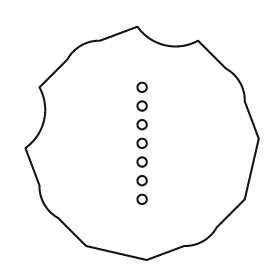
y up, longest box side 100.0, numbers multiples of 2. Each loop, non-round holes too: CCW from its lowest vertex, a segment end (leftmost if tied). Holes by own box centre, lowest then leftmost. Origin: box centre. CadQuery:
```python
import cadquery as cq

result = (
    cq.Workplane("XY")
    .moveTo(2.0, -50.0)
    .lineTo(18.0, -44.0)
    .threePointArc((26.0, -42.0), (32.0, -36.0))
    .lineTo(44.0, -24.0)
    .lineTo(50.0, 2.0)
    .lineTo(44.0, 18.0)
    .threePointArc((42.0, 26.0), (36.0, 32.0))
    .lineTo(24.0, 44.0)
    .threePointArc((10.0, 42.0), (-2.0, 50.0))
    .lineTo(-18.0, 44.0)
    .threePointArc((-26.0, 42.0), (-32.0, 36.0))
    .lineTo(-44.0, 24.0)
    .threePointArc((-42.0, 10.0), (-50.0, -2.0))
    .lineTo(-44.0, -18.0)
    .threePointArc((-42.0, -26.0), (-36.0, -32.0))
    .lineTo(-24.0, -44.0)
    .close()
    .moveTo(0.0, -24.0)
    .circle(2.0)
    .moveTo(0.0, -16.0)
    .circle(2.0)
    .moveTo(0.0, -8.0)
    .circle(2.0)
    .moveTo(0.0, 0.0)
    .circle(2.0)
    .moveTo(0.0, 8.0)
    .circle(2.0)
    .moveTo(0.0, 16.0)
    .circle(2.0)
    .moveTo(0.0, 24.0)
    .circle(2.0)
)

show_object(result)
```